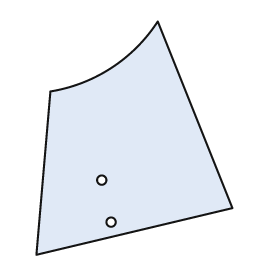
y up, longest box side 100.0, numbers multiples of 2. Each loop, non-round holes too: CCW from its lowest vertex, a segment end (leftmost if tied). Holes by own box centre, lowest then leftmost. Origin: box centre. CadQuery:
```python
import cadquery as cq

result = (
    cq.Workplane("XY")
    .moveTo(-42.0, -50.0)
    .lineTo(42.0, -30.0)
    .lineTo(10.0, 50.0)
    .threePointArc((-10.0, 30.0), (-36.0, 20.0))
    .close()
    .moveTo(-10.0, -36.0)
    .circle(2.0)
    .moveTo(-14.0, -18.0)
    .circle(2.0)
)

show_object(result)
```